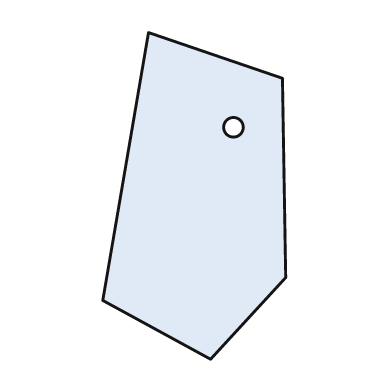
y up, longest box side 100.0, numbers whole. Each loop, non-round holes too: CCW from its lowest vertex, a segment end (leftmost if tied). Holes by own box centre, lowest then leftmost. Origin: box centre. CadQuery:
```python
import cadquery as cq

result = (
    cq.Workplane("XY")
    .moveTo(5.0, -50.0)
    .lineTo(28.0, -25.0)
    .lineTo(27.0, 36.0)
    .lineTo(-14.0, 50.0)
    .lineTo(-28.0, -32.0)
    .close()
    .moveTo(12.0, 21.0)
    .circle(3.0)
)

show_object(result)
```